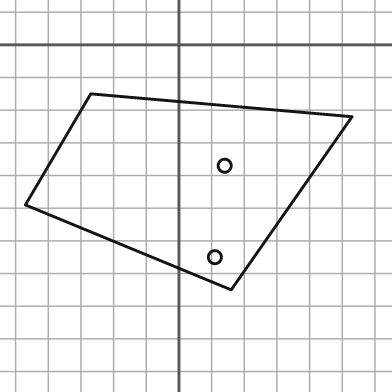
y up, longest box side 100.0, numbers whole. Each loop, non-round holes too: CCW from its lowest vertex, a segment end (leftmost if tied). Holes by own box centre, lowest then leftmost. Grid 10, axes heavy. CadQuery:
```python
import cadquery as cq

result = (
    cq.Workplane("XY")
    .moveTo(16.0, -75.0)
    .lineTo(53.0, -22.0)
    .lineTo(-27.0, -15.0)
    .lineTo(-47.0, -49.0)
    .close()
    .moveTo(11.0, -65.0)
    .circle(2.0)
    .moveTo(14.0, -37.0)
    .circle(2.0)
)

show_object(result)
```